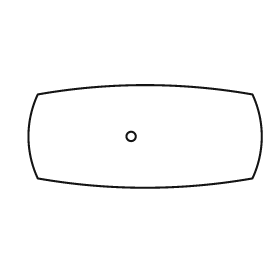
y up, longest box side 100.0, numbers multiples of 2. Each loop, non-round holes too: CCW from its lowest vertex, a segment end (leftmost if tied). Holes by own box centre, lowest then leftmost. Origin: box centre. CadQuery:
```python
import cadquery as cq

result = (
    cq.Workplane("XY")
    .moveTo(-46.0, -18.0)
    .threePointArc((0.0, -22.0), (46.0, -18.0))
    .threePointArc((50.0, 0.0), (46.0, 18.0))
    .threePointArc((0.0, 22.0), (-46.0, 18.0))
    .threePointArc((-50.0, 0.0), (-46.0, -18.0))
    .close()
    .moveTo(-6.0, 0.0)
    .circle(2.0)
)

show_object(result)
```